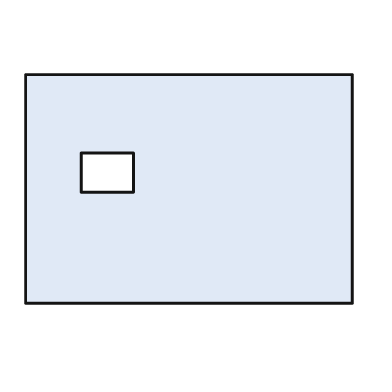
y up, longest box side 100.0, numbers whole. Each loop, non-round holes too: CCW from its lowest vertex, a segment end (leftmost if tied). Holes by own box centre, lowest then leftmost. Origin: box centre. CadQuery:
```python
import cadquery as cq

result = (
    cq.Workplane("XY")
    .moveTo(-50.0, -35.0)
    .lineTo(50.0, -35.0)
    .lineTo(50.0, 35.0)
    .lineTo(-50.0, 35.0)
    .close()
    .moveTo(-33.0, -1.0)
    .lineTo(-17.0, -1.0)
    .lineTo(-17.0, 11.0)
    .lineTo(-33.0, 11.0)
    .close()
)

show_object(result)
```